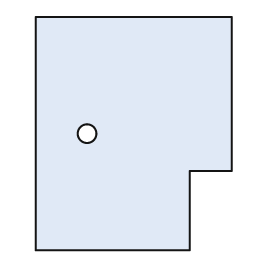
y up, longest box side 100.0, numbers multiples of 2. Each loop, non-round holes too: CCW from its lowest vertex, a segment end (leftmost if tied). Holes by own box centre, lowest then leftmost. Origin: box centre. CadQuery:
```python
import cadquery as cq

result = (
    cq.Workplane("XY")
    .moveTo(-42.0, -50.0)
    .lineTo(24.0, -50.0)
    .lineTo(24.0, -16.0)
    .lineTo(42.0, -16.0)
    .lineTo(42.0, 50.0)
    .lineTo(-42.0, 50.0)
    .close()
    .moveTo(-20.0, 0.0)
    .circle(4.0)
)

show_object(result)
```